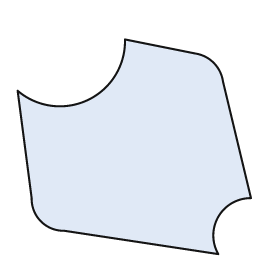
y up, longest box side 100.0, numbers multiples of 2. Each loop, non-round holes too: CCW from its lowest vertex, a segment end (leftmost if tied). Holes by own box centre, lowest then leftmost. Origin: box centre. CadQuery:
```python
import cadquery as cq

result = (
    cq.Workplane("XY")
    .moveTo(36.0, -46.0)
    .threePointArc((36.0, -30.0), (50.0, -22.0))
    .lineTo(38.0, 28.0)
    .threePointArc((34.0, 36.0), (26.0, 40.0))
    .lineTo(-4.0, 46.0)
    .threePointArc((-20.0, 20.0), (-50.0, 24.0))
    .lineTo(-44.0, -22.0)
    .threePointArc((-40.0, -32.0), (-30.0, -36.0))
    .close()
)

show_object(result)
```